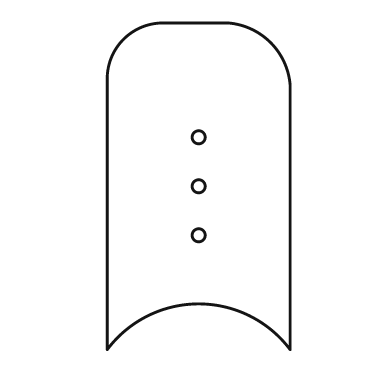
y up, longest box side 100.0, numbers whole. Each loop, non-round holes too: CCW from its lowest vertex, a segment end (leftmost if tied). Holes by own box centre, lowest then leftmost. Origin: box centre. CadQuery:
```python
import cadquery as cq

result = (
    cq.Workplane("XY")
    .moveTo(-28.0, -50.0)
    .threePointArc((0.0, -36.0), (28.0, -50.0))
    .lineTo(28.0, 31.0)
    .threePointArc((22.0, 44.0), (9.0, 50.0))
    .lineTo(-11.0, 50.0)
    .threePointArc((-23.0, 45.0), (-28.0, 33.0))
    .close()
    .moveTo(0.0, -15.0)
    .circle(2.0)
    .moveTo(0.0, 0.0)
    .circle(2.0)
    .moveTo(0.0, 15.0)
    .circle(2.0)
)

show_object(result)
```